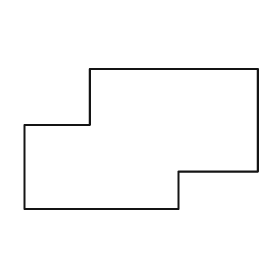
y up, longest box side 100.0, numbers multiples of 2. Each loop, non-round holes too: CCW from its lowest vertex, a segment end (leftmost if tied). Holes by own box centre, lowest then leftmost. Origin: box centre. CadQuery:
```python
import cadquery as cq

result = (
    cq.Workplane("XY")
    .moveTo(-50.0, -30.0)
    .lineTo(16.0, -30.0)
    .lineTo(16.0, -14.0)
    .lineTo(50.0, -14.0)
    .lineTo(50.0, 30.0)
    .lineTo(-22.0, 30.0)
    .lineTo(-22.0, 6.0)
    .lineTo(-50.0, 6.0)
    .close()
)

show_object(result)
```